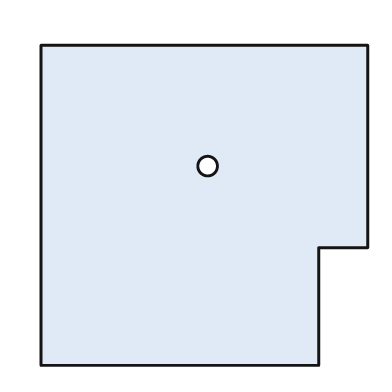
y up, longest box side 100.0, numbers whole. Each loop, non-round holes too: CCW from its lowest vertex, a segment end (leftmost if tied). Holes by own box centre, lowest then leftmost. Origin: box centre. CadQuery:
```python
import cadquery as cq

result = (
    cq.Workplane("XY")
    .moveTo(-50.0, -49.0)
    .lineTo(35.0, -49.0)
    .lineTo(35.0, -13.0)
    .lineTo(50.0, -13.0)
    .lineTo(50.0, 49.0)
    .lineTo(-50.0, 49.0)
    .close()
    .moveTo(1.0, 12.0)
    .circle(3.0)
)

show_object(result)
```